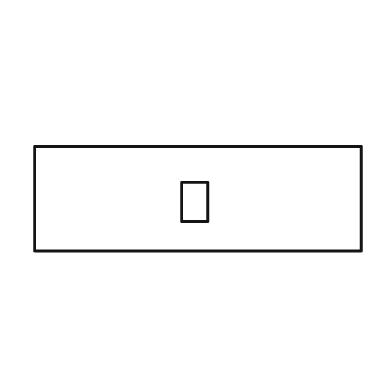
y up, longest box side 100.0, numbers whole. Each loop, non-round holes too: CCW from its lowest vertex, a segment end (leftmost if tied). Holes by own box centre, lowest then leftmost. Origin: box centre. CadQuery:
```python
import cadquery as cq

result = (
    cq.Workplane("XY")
    .moveTo(-50.0, -16.0)
    .lineTo(50.0, -16.0)
    .lineTo(50.0, 16.0)
    .lineTo(-50.0, 16.0)
    .close()
    .moveTo(-5.0, -7.0)
    .lineTo(3.0, -7.0)
    .lineTo(3.0, 5.0)
    .lineTo(-5.0, 5.0)
    .close()
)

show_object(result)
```